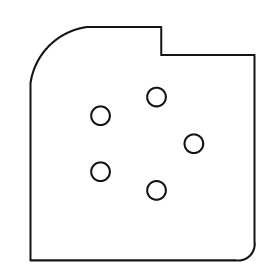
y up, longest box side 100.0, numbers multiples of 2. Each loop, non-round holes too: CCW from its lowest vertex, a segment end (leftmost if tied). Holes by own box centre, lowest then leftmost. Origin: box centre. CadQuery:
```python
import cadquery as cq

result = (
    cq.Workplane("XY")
    .moveTo(-48.0, -50.0)
    .lineTo(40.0, -50.0)
    .threePointArc((46.0, -48.0), (48.0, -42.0))
    .lineTo(48.0, 38.0)
    .lineTo(8.0, 38.0)
    .lineTo(8.0, 50.0)
    .lineTo(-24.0, 50.0)
    .threePointArc((-40.0, 42.0), (-48.0, 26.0))
    .close()
    .moveTo(6.0, -20.0)
    .circle(4.0)
    .moveTo(-18.0, -12.0)
    .circle(4.0)
    .moveTo(22.0, 0.0)
    .circle(4.0)
    .moveTo(-18.0, 12.0)
    .circle(4.0)
    .moveTo(6.0, 20.0)
    .circle(4.0)
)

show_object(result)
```